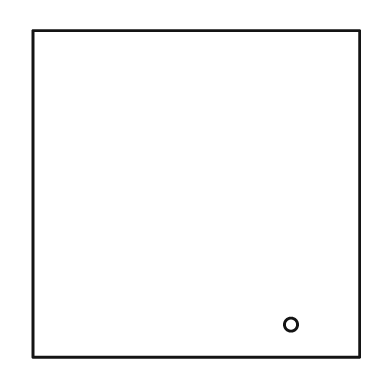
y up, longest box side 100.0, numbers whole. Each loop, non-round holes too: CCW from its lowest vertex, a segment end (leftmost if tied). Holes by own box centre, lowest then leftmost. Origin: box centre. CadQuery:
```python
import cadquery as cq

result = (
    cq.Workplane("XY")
    .moveTo(-50.0, -50.0)
    .lineTo(50.0, -50.0)
    .lineTo(50.0, 50.0)
    .lineTo(-50.0, 50.0)
    .close()
    .moveTo(29.0, -40.0)
    .circle(2.0)
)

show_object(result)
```